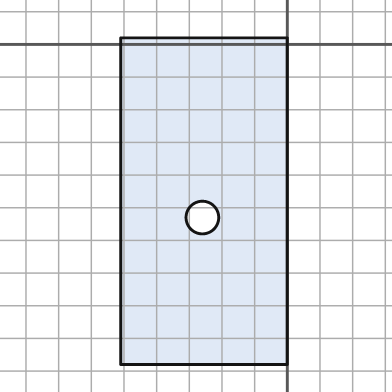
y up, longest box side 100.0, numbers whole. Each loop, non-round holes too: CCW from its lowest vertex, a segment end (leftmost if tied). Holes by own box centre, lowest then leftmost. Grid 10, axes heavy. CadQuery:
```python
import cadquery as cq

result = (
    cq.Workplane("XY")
    .moveTo(-51.0, -98.0)
    .lineTo(0.0, -98.0)
    .lineTo(0.0, 2.0)
    .lineTo(-51.0, 2.0)
    .close()
    .moveTo(-26.0, -53.0)
    .circle(5.0)
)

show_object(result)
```